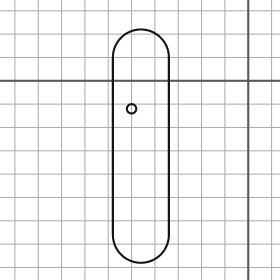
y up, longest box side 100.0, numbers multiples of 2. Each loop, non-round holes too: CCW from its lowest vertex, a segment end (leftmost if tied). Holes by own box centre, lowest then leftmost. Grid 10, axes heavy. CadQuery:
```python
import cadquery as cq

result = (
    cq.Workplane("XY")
    .moveTo(-58.0, -66.0)
    .threePointArc((-46.0, -78.0), (-34.0, -66.0))
    .lineTo(-34.0, 10.0)
    .threePointArc((-46.0, 22.0), (-58.0, 10.0))
    .close()
    .moveTo(-50.0, -12.0)
    .circle(2.0)
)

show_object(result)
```